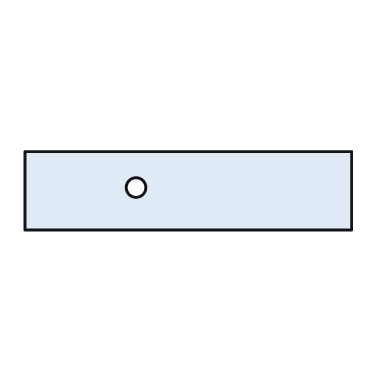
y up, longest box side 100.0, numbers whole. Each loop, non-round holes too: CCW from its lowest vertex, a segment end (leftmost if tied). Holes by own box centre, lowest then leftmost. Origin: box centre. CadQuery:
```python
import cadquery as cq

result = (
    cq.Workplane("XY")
    .moveTo(-50.0, -12.0)
    .lineTo(50.0, -12.0)
    .lineTo(50.0, 12.0)
    .lineTo(-50.0, 12.0)
    .close()
    .moveTo(-16.0, 1.0)
    .circle(3.0)
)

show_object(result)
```